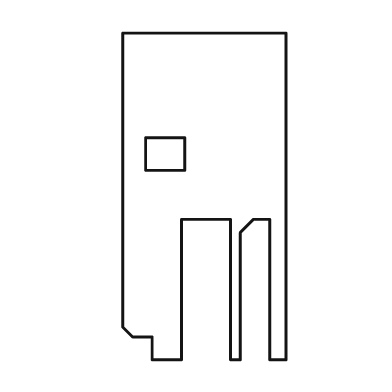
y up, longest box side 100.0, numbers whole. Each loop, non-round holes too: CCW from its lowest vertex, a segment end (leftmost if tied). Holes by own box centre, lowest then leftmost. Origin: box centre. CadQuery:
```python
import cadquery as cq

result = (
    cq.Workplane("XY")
    .moveTo(-16.0, -50.0)
    .lineTo(-7.0, -50.0)
    .lineTo(-7.0, -7.0)
    .lineTo(8.0, -7.0)
    .lineTo(8.0, -50.0)
    .lineTo(11.0, -50.0)
    .lineTo(11.0, -11.0)
    .lineTo(15.0, -7.0)
    .lineTo(20.0, -7.0)
    .lineTo(20.0, -50.0)
    .lineTo(25.0, -50.0)
    .lineTo(25.0, 50.0)
    .lineTo(-25.0, 50.0)
    .lineTo(-25.0, -40.0)
    .lineTo(-22.0, -43.0)
    .lineTo(-16.0, -43.0)
    .close()
    .moveTo(-18.0, 8.0)
    .lineTo(-6.0, 8.0)
    .lineTo(-6.0, 18.0)
    .lineTo(-18.0, 18.0)
    .close()
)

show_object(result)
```